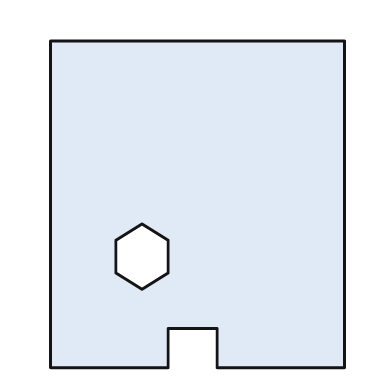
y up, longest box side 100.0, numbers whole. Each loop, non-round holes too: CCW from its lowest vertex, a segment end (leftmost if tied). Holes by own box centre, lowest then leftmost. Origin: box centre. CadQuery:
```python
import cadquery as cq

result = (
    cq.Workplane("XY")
    .moveTo(-45.0, -50.0)
    .lineTo(-9.0, -50.0)
    .lineTo(-9.0, -38.0)
    .lineTo(6.0, -38.0)
    .lineTo(6.0, -50.0)
    .lineTo(45.0, -50.0)
    .lineTo(45.0, 50.0)
    .lineTo(-45.0, 50.0)
    .close()
    .moveTo(-17.0, -26.0)
    .lineTo(-9.0, -21.0)
    .lineTo(-9.0, -11.0)
    .lineTo(-17.0, -6.0)
    .lineTo(-25.0, -11.0)
    .lineTo(-25.0, -21.0)
    .close()
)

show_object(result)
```